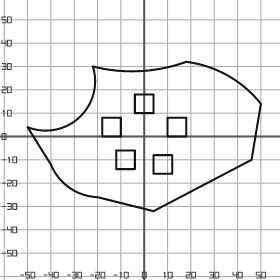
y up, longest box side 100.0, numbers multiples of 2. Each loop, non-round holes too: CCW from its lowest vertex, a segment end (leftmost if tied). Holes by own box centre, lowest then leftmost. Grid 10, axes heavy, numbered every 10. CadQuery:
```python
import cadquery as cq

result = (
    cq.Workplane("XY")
    .moveTo(4.0, -32.0)
    .lineTo(46.0, -10.0)
    .lineTo(50.0, 14.0)
    .threePointArc((36.0, 26.0), (18.0, 32.0))
    .threePointArc((-2.0, 28.0), (-22.0, 30.0))
    .threePointArc((-28.0, 8.0), (-50.0, 4.0))
    .lineTo(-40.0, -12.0)
    .threePointArc((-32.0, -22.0), (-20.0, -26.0))
    .close()
    .moveTo(4.0, -16.0)
    .lineTo(12.0, -16.0)
    .lineTo(12.0, -8.0)
    .lineTo(4.0, -8.0)
    .close()
    .moveTo(-12.0, -14.0)
    .lineTo(-4.0, -14.0)
    .lineTo(-4.0, -6.0)
    .lineTo(-12.0, -6.0)
    .close()
    .moveTo(-18.0, 0.0)
    .lineTo(-10.0, 0.0)
    .lineTo(-10.0, 8.0)
    .lineTo(-18.0, 8.0)
    .close()
    .moveTo(10.0, 0.0)
    .lineTo(18.0, 0.0)
    .lineTo(18.0, 8.0)
    .lineTo(10.0, 8.0)
    .close()
    .moveTo(-4.0, 10.0)
    .lineTo(4.0, 10.0)
    .lineTo(4.0, 18.0)
    .lineTo(-4.0, 18.0)
    .close()
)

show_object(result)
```